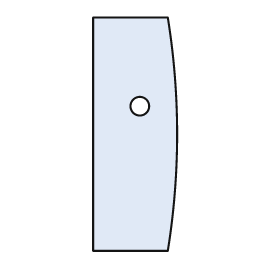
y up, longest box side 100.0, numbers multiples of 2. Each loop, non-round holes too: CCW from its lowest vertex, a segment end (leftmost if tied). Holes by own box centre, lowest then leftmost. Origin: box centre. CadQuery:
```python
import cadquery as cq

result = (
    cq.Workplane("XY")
    .moveTo(-18.0, -50.0)
    .lineTo(14.0, -50.0)
    .threePointArc((18.0, 0.0), (14.0, 50.0))
    .lineTo(-18.0, 50.0)
    .close()
    .moveTo(2.0, 12.0)
    .circle(4.0)
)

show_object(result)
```